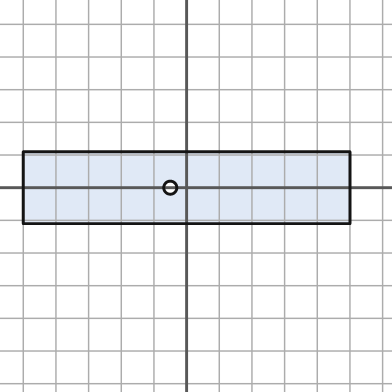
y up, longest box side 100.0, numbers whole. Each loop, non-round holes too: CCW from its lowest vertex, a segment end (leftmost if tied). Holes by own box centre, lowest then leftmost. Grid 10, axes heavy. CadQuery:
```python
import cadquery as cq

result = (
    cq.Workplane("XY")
    .moveTo(-50.0, -11.0)
    .lineTo(50.0, -11.0)
    .lineTo(50.0, 11.0)
    .lineTo(-50.0, 11.0)
    .close()
    .moveTo(-5.0, 0.0)
    .circle(2.0)
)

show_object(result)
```